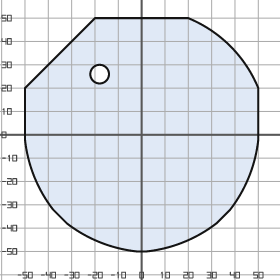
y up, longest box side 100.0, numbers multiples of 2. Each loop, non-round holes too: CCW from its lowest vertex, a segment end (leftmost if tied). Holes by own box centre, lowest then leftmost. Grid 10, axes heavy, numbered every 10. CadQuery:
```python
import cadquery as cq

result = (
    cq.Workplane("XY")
    .moveTo(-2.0, -50.0)
    .lineTo(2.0, -50.0)
    .threePointArc((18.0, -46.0), (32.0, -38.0))
    .lineTo(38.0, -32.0)
    .threePointArc((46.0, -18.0), (50.0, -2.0))
    .lineTo(50.0, 20.0)
    .threePointArc((38.0, 38.0), (20.0, 50.0))
    .lineTo(-20.0, 50.0)
    .lineTo(-50.0, 20.0)
    .lineTo(-50.0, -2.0)
    .threePointArc((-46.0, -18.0), (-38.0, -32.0))
    .lineTo(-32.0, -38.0)
    .threePointArc((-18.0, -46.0), (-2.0, -50.0))
    .close()
    .moveTo(-18.0, 26.0)
    .circle(4.0)
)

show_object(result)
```